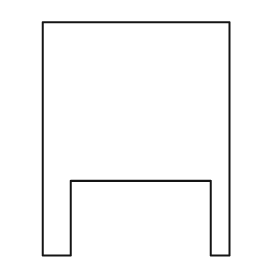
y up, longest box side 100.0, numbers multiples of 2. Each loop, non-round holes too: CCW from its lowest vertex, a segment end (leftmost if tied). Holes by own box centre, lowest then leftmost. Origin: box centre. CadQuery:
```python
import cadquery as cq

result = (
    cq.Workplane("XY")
    .moveTo(-40.0, -50.0)
    .lineTo(-28.0, -50.0)
    .lineTo(-28.0, -18.0)
    .lineTo(32.0, -18.0)
    .lineTo(32.0, -50.0)
    .lineTo(40.0, -50.0)
    .lineTo(40.0, 50.0)
    .lineTo(-40.0, 50.0)
    .close()
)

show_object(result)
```